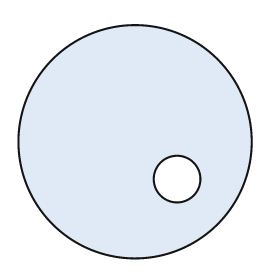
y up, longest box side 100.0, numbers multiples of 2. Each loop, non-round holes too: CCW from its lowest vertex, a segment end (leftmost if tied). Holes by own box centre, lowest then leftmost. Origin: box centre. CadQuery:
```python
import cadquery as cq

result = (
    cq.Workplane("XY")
    .moveTo(0.0, 0.0)
    .circle(50.0)
    .moveTo(18.0, -16.0)
    .circle(10.0)
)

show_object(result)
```